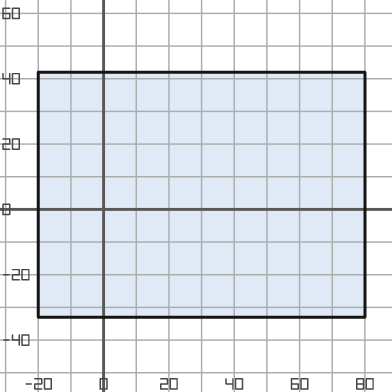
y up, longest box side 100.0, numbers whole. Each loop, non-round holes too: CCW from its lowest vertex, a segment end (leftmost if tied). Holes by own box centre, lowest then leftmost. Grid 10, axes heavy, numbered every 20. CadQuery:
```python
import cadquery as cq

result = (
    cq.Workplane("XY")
    .moveTo(-20.0, -33.0)
    .lineTo(80.0, -33.0)
    .lineTo(80.0, 42.0)
    .lineTo(-20.0, 42.0)
    .close()
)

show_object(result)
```